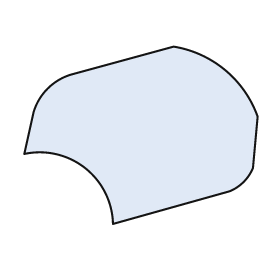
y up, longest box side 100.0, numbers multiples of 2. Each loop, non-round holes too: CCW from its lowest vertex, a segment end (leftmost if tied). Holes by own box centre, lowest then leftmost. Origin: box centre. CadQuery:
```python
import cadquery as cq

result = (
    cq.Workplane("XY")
    .moveTo(-12.0, -38.0)
    .lineTo(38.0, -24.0)
    .threePointArc((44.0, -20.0), (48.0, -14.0))
    .lineTo(50.0, 8.0)
    .threePointArc((36.0, 28.0), (14.0, 38.0))
    .lineTo(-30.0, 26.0)
    .threePointArc((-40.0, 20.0), (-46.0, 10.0))
    .lineTo(-50.0, -8.0)
    .threePointArc((-24.0, -14.0), (-12.0, -38.0))
    .close()
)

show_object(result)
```